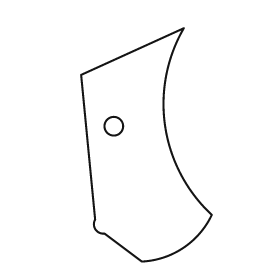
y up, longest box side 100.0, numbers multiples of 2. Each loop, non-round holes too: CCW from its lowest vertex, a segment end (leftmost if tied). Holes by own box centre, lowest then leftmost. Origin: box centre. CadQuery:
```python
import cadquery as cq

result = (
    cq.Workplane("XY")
    .moveTo(-2.0, -50.0)
    .threePointArc((16.0, -44.0), (28.0, -30.0))
    .threePointArc((8.0, 8.0), (16.0, 50.0))
    .lineTo(-28.0, 30.0)
    .lineTo(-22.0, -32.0)
    .threePointArc((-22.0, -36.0), (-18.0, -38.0))
    .close()
    .moveTo(-14.0, 8.0)
    .circle(4.0)
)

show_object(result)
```